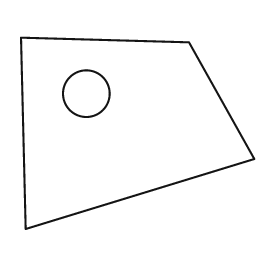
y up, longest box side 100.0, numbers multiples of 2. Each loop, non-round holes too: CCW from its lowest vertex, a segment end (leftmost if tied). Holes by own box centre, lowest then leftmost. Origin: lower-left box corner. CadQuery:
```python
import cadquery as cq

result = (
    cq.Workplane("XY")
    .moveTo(2.0, 0.0)
    .lineTo(100.0, 30.0)
    .lineTo(72.0, 80.0)
    .lineTo(0.0, 82.0)
    .close()
    .moveTo(28.0, 58.0)
    .circle(10.0)
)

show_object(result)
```